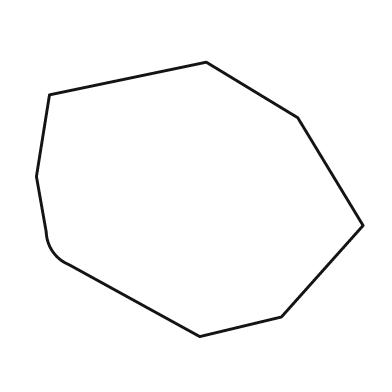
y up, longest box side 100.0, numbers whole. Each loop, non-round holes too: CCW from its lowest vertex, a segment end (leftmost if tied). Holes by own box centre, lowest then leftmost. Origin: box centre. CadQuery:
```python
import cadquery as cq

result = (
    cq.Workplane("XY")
    .moveTo(0.0, -42.0)
    .lineTo(25.0, -36.0)
    .lineTo(50.0, -8.0)
    .lineTo(30.0, 25.0)
    .lineTo(2.0, 42.0)
    .lineTo(-46.0, 32.0)
    .lineTo(-50.0, 7.0)
    .lineTo(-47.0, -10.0)
    .threePointArc((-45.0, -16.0), (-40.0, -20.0))
    .close()
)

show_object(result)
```